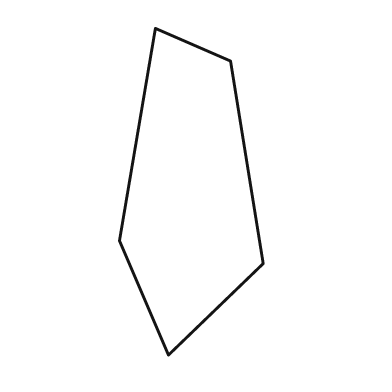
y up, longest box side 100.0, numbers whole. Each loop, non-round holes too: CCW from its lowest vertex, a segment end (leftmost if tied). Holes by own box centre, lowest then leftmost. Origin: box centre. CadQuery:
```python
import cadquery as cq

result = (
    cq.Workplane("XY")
    .moveTo(-7.0, -50.0)
    .lineTo(22.0, -22.0)
    .lineTo(12.0, 40.0)
    .lineTo(-11.0, 50.0)
    .lineTo(-22.0, -15.0)
    .close()
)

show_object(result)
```